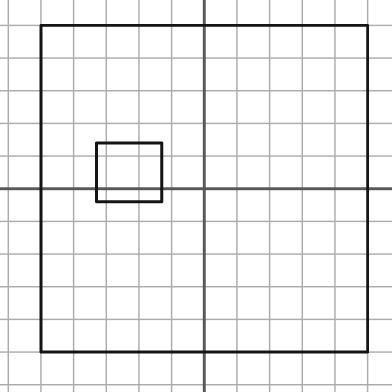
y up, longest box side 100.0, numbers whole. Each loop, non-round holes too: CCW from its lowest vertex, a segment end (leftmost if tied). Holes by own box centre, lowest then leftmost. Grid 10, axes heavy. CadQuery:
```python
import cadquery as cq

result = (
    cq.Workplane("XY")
    .moveTo(-50.0, -50.0)
    .lineTo(50.0, -50.0)
    .lineTo(50.0, 50.0)
    .lineTo(-50.0, 50.0)
    .close()
    .moveTo(-33.0, -4.0)
    .lineTo(-13.0, -4.0)
    .lineTo(-13.0, 14.0)
    .lineTo(-33.0, 14.0)
    .close()
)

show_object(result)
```